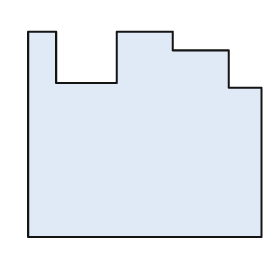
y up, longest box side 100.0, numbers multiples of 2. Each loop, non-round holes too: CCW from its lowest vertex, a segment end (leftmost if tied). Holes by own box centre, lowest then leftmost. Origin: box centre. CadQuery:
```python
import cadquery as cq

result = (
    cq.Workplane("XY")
    .moveTo(-50.0, -44.0)
    .lineTo(50.0, -44.0)
    .lineTo(50.0, 20.0)
    .lineTo(36.0, 20.0)
    .lineTo(36.0, 36.0)
    .lineTo(12.0, 36.0)
    .lineTo(12.0, 44.0)
    .lineTo(-12.0, 44.0)
    .lineTo(-12.0, 22.0)
    .lineTo(-38.0, 22.0)
    .lineTo(-38.0, 44.0)
    .lineTo(-50.0, 44.0)
    .close()
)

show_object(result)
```